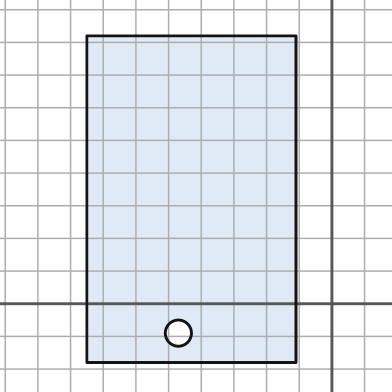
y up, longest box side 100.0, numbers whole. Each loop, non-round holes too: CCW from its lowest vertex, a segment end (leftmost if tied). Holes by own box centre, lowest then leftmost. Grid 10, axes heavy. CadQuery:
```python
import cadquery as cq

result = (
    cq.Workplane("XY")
    .moveTo(-75.0, -18.0)
    .lineTo(-11.0, -18.0)
    .lineTo(-11.0, 82.0)
    .lineTo(-75.0, 82.0)
    .close()
    .moveTo(-47.0, -9.0)
    .circle(4.0)
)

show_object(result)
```